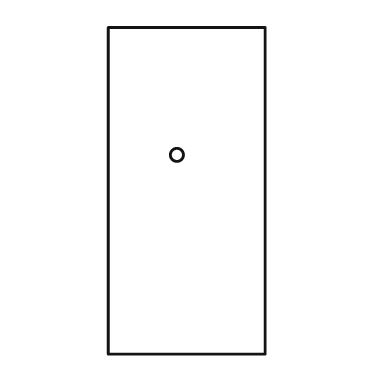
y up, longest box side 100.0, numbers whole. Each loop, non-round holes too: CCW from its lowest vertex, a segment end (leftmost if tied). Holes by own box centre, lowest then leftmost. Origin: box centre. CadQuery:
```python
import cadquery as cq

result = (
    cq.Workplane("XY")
    .moveTo(-24.0, -50.0)
    .lineTo(24.0, -50.0)
    .lineTo(24.0, 50.0)
    .lineTo(-24.0, 50.0)
    .close()
    .moveTo(-3.0, 11.0)
    .circle(2.0)
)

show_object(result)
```